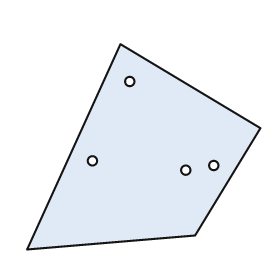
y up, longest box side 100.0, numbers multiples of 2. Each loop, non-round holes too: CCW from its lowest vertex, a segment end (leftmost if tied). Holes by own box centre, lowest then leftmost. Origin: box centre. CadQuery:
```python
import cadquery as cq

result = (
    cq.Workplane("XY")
    .moveTo(-50.0, -44.0)
    .lineTo(22.0, -38.0)
    .lineTo(50.0, 8.0)
    .lineTo(-10.0, 44.0)
    .close()
    .moveTo(18.0, -10.0)
    .circle(2.0)
    .moveTo(30.0, -8.0)
    .circle(2.0)
    .moveTo(-22.0, -6.0)
    .circle(2.0)
    .moveTo(-6.0, 28.0)
    .circle(2.0)
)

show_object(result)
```